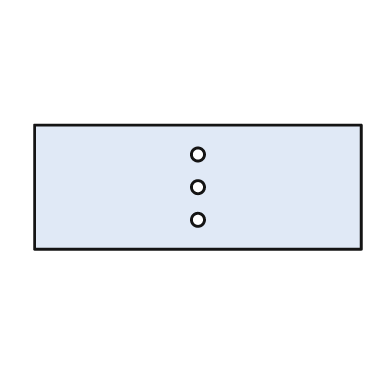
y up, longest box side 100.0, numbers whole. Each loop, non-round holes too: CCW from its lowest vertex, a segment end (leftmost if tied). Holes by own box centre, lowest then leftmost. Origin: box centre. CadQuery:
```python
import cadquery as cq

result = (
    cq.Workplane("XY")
    .moveTo(-50.0, -19.0)
    .lineTo(50.0, -19.0)
    .lineTo(50.0, 19.0)
    .lineTo(-50.0, 19.0)
    .close()
    .moveTo(0.0, -10.0)
    .circle(2.0)
    .moveTo(0.0, 0.0)
    .circle(2.0)
    .moveTo(0.0, 10.0)
    .circle(2.0)
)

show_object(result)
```